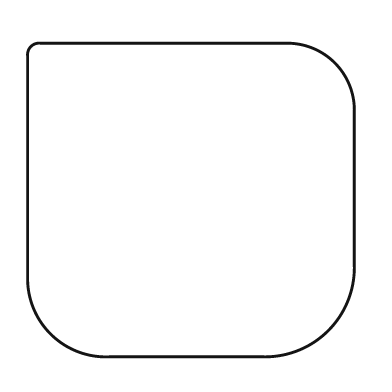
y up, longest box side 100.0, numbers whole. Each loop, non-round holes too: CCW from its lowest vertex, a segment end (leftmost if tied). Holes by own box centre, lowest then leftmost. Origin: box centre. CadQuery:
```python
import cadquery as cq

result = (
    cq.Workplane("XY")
    .moveTo(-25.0, -48.0)
    .lineTo(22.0, -48.0)
    .threePointArc((42.0, -40.0), (50.0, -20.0))
    .lineTo(50.0, 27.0)
    .threePointArc((44.0, 42.0), (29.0, 48.0))
    .lineTo(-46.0, 48.0)
    .threePointArc((-49.0, 47.0), (-50.0, 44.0))
    .lineTo(-50.0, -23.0)
    .threePointArc((-43.0, -41.0), (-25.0, -48.0))
    .close()
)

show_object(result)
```